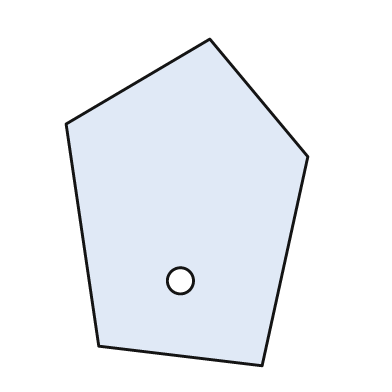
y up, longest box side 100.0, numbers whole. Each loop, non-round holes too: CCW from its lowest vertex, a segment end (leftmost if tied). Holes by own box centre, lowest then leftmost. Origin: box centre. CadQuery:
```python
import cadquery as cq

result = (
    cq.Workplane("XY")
    .moveTo(23.0, -50.0)
    .lineTo(37.0, 14.0)
    .lineTo(7.0, 50.0)
    .lineTo(-37.0, 24.0)
    .lineTo(-27.0, -44.0)
    .close()
    .moveTo(-2.0, -24.0)
    .circle(4.0)
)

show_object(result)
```